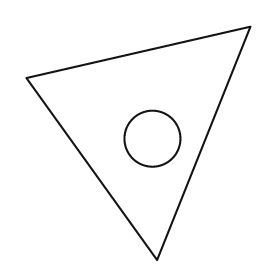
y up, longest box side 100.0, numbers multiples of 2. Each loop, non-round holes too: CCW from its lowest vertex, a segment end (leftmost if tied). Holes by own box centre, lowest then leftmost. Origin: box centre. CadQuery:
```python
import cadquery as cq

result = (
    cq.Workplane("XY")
    .moveTo(8.0, -50.0)
    .lineTo(48.0, 50.0)
    .lineTo(-48.0, 28.0)
    .close()
    .moveTo(6.0, 2.0)
    .circle(12.0)
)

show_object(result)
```